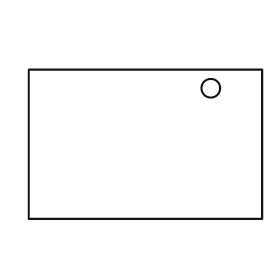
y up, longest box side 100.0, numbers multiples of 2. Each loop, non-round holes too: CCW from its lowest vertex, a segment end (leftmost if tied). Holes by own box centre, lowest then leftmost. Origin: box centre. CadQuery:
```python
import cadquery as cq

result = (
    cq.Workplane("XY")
    .moveTo(-50.0, -32.0)
    .lineTo(50.0, -32.0)
    .lineTo(50.0, 32.0)
    .lineTo(-50.0, 32.0)
    .close()
    .moveTo(28.0, 24.0)
    .circle(4.0)
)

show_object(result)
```